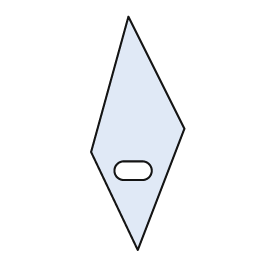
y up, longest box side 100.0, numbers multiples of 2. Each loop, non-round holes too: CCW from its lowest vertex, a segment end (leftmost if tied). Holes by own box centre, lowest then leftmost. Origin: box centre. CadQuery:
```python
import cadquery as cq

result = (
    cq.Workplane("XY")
    .moveTo(0.0, -50.0)
    .lineTo(20.0, 2.0)
    .lineTo(-4.0, 50.0)
    .lineTo(-20.0, -8.0)
    .close()
    .moveTo(-6.0, -20.0)
    .lineTo(2.0, -20.0)
    .threePointArc((6.0, -16.0), (2.0, -12.0))
    .lineTo(-6.0, -12.0)
    .threePointArc((-10.0, -16.0), (-6.0, -20.0))
    .close()
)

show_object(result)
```